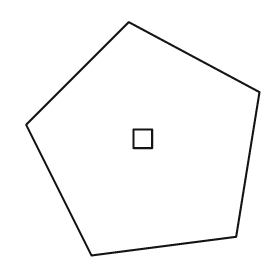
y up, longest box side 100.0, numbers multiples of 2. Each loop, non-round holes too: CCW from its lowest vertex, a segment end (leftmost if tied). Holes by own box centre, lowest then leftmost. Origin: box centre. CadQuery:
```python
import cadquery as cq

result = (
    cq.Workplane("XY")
    .moveTo(-22.0, -50.0)
    .lineTo(40.0, -42.0)
    .lineTo(50.0, 20.0)
    .lineTo(-6.0, 50.0)
    .lineTo(-50.0, 6.0)
    .close()
    .moveTo(-4.0, -4.0)
    .lineTo(4.0, -4.0)
    .lineTo(4.0, 4.0)
    .lineTo(-4.0, 4.0)
    .close()
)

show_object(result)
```